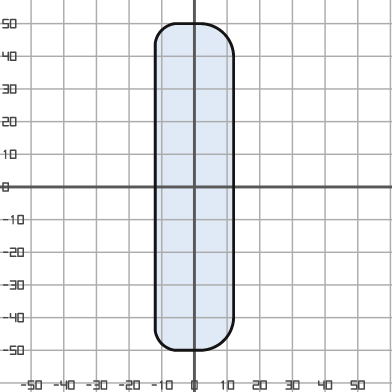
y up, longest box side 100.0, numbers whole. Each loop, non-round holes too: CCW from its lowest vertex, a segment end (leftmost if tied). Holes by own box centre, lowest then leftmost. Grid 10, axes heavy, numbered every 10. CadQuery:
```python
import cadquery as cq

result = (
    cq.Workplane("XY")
    .moveTo(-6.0, -50.0)
    .lineTo(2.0, -50.0)
    .threePointArc((9.0, -47.0), (12.0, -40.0))
    .lineTo(12.0, 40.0)
    .threePointArc((9.0, 47.0), (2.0, 50.0))
    .lineTo(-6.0, 50.0)
    .threePointArc((-10.0, 48.0), (-12.0, 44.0))
    .lineTo(-12.0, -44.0)
    .threePointArc((-10.0, -48.0), (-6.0, -50.0))
    .close()
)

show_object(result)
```